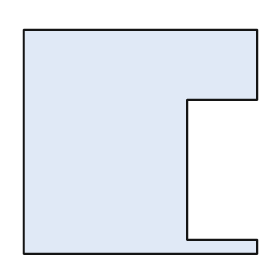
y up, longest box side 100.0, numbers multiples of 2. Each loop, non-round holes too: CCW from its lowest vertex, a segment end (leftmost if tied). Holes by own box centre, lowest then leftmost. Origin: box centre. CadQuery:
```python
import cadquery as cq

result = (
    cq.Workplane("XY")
    .moveTo(-50.0, -48.0)
    .lineTo(50.0, -48.0)
    .lineTo(50.0, -42.0)
    .lineTo(20.0, -42.0)
    .lineTo(20.0, 18.0)
    .lineTo(50.0, 18.0)
    .lineTo(50.0, 48.0)
    .lineTo(-50.0, 48.0)
    .close()
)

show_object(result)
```